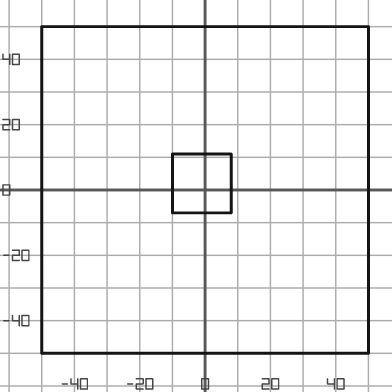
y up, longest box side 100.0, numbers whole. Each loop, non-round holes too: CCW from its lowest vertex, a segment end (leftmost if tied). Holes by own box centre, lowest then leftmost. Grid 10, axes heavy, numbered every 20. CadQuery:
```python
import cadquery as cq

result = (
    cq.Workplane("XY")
    .moveTo(-50.0, -50.0)
    .lineTo(50.0, -50.0)
    .lineTo(50.0, 50.0)
    .lineTo(-50.0, 50.0)
    .close()
    .moveTo(-10.0, -7.0)
    .lineTo(8.0, -7.0)
    .lineTo(8.0, 11.0)
    .lineTo(-10.0, 11.0)
    .close()
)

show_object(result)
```